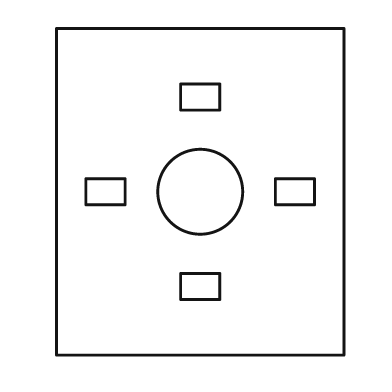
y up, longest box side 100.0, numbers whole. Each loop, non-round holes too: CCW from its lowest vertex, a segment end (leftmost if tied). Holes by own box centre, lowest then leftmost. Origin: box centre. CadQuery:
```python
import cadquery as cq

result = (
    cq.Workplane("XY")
    .moveTo(-44.0, -50.0)
    .lineTo(44.0, -50.0)
    .lineTo(44.0, 50.0)
    .lineTo(-44.0, 50.0)
    .close()
    .moveTo(-6.0, -33.0)
    .lineTo(6.0, -33.0)
    .lineTo(6.0, -25.0)
    .lineTo(-6.0, -25.0)
    .close()
    .moveTo(-35.0, -4.0)
    .lineTo(-23.0, -4.0)
    .lineTo(-23.0, 4.0)
    .lineTo(-35.0, 4.0)
    .close()
    .moveTo(0.0, 0.0)
    .circle(13.0)
    .moveTo(23.0, -4.0)
    .lineTo(35.0, -4.0)
    .lineTo(35.0, 4.0)
    .lineTo(23.0, 4.0)
    .close()
    .moveTo(-6.0, 25.0)
    .lineTo(6.0, 25.0)
    .lineTo(6.0, 33.0)
    .lineTo(-6.0, 33.0)
    .close()
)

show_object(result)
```